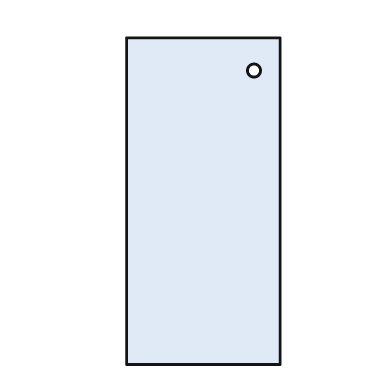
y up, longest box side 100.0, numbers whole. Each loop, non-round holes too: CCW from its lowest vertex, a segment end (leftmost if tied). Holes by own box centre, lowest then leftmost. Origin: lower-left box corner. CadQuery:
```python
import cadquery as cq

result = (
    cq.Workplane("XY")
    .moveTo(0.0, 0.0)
    .lineTo(47.0, 0.0)
    .lineTo(47.0, 100.0)
    .lineTo(0.0, 100.0)
    .close()
    .moveTo(39.0, 90.0)
    .circle(2.0)
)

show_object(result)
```